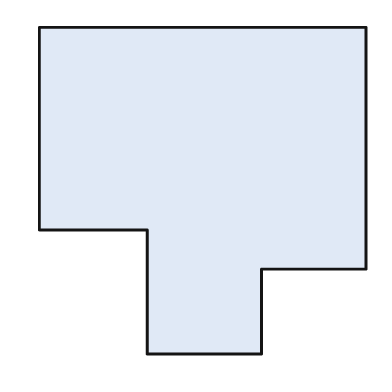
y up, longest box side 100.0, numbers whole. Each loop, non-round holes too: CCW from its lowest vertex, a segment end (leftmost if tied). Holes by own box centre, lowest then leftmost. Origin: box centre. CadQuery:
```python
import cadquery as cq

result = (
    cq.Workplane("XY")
    .moveTo(-17.0, -50.0)
    .lineTo(18.0, -50.0)
    .lineTo(18.0, -24.0)
    .lineTo(50.0, -24.0)
    .lineTo(50.0, 50.0)
    .lineTo(-50.0, 50.0)
    .lineTo(-50.0, -12.0)
    .lineTo(-17.0, -12.0)
    .close()
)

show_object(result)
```